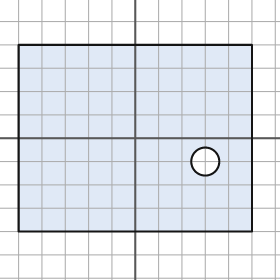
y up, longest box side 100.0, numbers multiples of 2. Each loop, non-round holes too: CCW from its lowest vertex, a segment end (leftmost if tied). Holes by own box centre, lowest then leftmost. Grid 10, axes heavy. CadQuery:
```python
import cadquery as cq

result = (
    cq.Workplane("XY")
    .moveTo(-50.0, -40.0)
    .lineTo(50.0, -40.0)
    .lineTo(50.0, 40.0)
    .lineTo(-50.0, 40.0)
    .close()
    .moveTo(30.0, -10.0)
    .circle(6.0)
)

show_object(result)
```